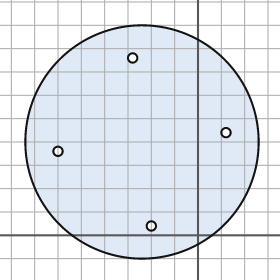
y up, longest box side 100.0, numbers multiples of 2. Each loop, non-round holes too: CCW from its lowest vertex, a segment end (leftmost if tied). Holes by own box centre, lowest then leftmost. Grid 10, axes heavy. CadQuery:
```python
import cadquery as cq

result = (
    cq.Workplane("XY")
    .moveTo(-24.0, 40.0)
    .circle(50.0)
    .moveTo(-20.0, 4.0)
    .circle(2.0)
    .moveTo(-60.0, 36.0)
    .circle(2.0)
    .moveTo(12.0, 44.0)
    .circle(2.0)
    .moveTo(-28.0, 76.0)
    .circle(2.0)
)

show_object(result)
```